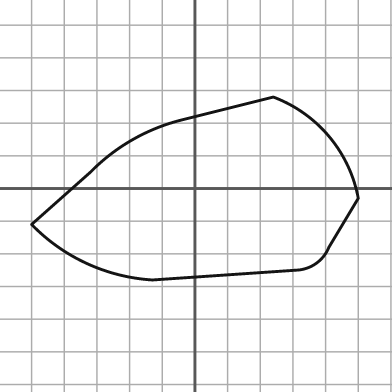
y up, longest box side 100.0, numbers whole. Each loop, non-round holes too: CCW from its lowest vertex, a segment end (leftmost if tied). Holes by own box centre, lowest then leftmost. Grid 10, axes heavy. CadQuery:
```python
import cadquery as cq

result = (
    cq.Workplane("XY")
    .moveTo(-13.0, -28.0)
    .lineTo(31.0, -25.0)
    .threePointArc((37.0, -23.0), (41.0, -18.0))
    .lineTo(50.0, -3.0)
    .threePointArc((41.0, 16.0), (24.0, 28.0))
    .lineTo(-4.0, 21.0)
    .threePointArc((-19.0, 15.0), (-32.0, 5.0))
    .lineTo(-50.0, -11.0)
    .threePointArc((-33.0, -23.0), (-13.0, -28.0))
    .close()
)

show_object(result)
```